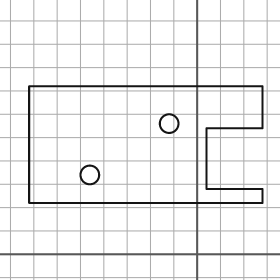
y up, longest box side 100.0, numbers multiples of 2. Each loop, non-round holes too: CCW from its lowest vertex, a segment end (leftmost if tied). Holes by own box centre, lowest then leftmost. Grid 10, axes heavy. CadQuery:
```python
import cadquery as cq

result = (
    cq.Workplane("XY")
    .moveTo(-72.0, 22.0)
    .lineTo(28.0, 22.0)
    .lineTo(28.0, 28.0)
    .lineTo(4.0, 28.0)
    .lineTo(4.0, 54.0)
    .lineTo(28.0, 54.0)
    .lineTo(28.0, 72.0)
    .lineTo(-72.0, 72.0)
    .close()
    .moveTo(-46.0, 34.0)
    .circle(4.0)
    .moveTo(-12.0, 56.0)
    .circle(4.0)
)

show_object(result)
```